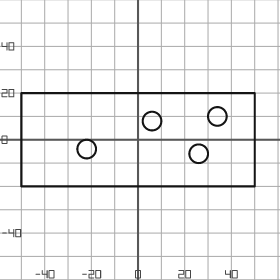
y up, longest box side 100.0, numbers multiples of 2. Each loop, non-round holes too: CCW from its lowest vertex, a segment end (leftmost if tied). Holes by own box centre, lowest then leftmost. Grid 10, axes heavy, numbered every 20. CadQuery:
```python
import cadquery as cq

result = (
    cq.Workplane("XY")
    .moveTo(-50.0, -20.0)
    .lineTo(50.0, -20.0)
    .lineTo(50.0, 20.0)
    .lineTo(-50.0, 20.0)
    .close()
    .moveTo(26.0, -6.0)
    .circle(4.0)
    .moveTo(-22.0, -4.0)
    .circle(4.0)
    .moveTo(6.0, 8.0)
    .circle(4.0)
    .moveTo(34.0, 10.0)
    .circle(4.0)
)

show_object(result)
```